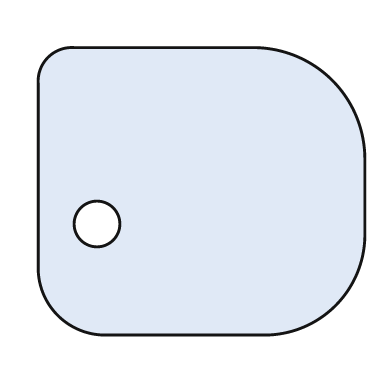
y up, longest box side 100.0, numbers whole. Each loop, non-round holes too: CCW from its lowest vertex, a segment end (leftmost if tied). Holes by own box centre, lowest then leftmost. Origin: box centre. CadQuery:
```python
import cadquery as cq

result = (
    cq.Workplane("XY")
    .moveTo(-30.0, -44.0)
    .lineTo(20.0, -44.0)
    .threePointArc((41.0, -35.0), (50.0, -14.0))
    .lineTo(50.0, 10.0)
    .threePointArc((40.0, 34.0), (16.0, 44.0))
    .lineTo(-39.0, 44.0)
    .threePointArc((-47.0, 41.0), (-50.0, 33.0))
    .lineTo(-50.0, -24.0)
    .threePointArc((-44.0, -38.0), (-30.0, -44.0))
    .close()
    .moveTo(-32.0, -10.0)
    .circle(7.0)
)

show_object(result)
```